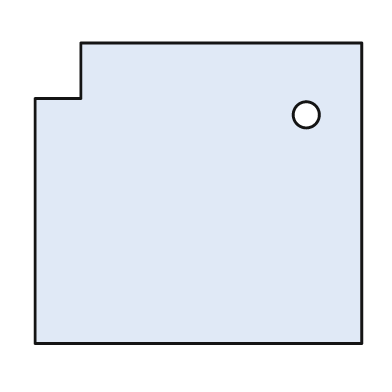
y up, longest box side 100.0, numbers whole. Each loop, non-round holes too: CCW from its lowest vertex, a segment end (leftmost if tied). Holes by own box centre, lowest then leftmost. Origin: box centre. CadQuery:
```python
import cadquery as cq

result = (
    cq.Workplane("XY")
    .moveTo(-50.0, -46.0)
    .lineTo(50.0, -46.0)
    .lineTo(50.0, 46.0)
    .lineTo(-36.0, 46.0)
    .lineTo(-36.0, 29.0)
    .lineTo(-50.0, 29.0)
    .close()
    .moveTo(33.0, 24.0)
    .circle(4.0)
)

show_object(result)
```